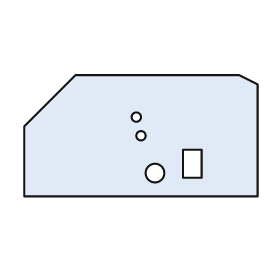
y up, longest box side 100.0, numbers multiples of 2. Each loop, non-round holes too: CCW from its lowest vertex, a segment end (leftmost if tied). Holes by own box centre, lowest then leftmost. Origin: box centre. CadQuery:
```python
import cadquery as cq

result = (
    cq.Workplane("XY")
    .moveTo(-50.0, -26.0)
    .lineTo(50.0, -26.0)
    .lineTo(50.0, 22.0)
    .lineTo(42.0, 26.0)
    .lineTo(-28.0, 26.0)
    .lineTo(-50.0, 4.0)
    .close()
    .moveTo(6.0, -16.0)
    .circle(4.0)
    .moveTo(18.0, -18.0)
    .lineTo(26.0, -18.0)
    .lineTo(26.0, -6.0)
    .lineTo(18.0, -6.0)
    .close()
    .moveTo(0.0, 0.0)
    .circle(2.0)
    .moveTo(-2.0, 8.0)
    .circle(2.0)
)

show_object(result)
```